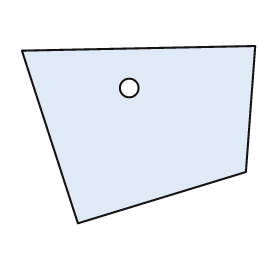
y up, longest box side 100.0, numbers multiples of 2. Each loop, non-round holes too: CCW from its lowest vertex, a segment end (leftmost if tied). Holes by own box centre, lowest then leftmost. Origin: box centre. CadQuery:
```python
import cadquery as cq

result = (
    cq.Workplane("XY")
    .moveTo(-26.0, -38.0)
    .lineTo(46.0, -16.0)
    .lineTo(50.0, 38.0)
    .lineTo(-50.0, 36.0)
    .close()
    .moveTo(-4.0, 20.0)
    .circle(4.0)
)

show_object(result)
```